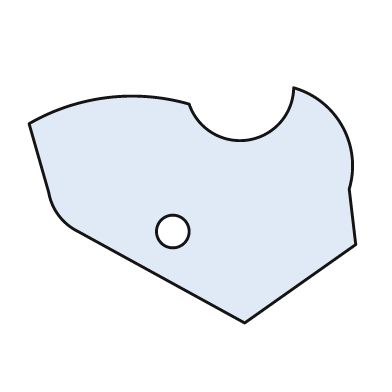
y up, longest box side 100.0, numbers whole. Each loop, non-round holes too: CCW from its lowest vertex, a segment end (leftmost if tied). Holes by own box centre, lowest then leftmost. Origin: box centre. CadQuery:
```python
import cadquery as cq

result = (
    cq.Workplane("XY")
    .moveTo(16.0, -36.0)
    .lineTo(50.0, -12.0)
    .lineTo(48.0, 5.0)
    .threePointArc((46.0, 24.0), (31.0, 36.0))
    .threePointArc((17.0, 20.0), (-1.0, 31.0))
    .threePointArc((-26.0, 33.0), (-50.0, 25.0))
    .lineTo(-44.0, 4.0)
    .threePointArc((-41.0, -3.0), (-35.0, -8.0))
    .close()
    .moveTo(-6.0, -8.0)
    .circle(5.0)
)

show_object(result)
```